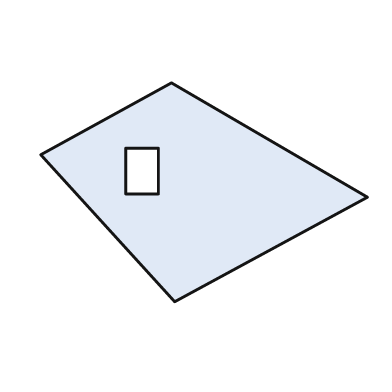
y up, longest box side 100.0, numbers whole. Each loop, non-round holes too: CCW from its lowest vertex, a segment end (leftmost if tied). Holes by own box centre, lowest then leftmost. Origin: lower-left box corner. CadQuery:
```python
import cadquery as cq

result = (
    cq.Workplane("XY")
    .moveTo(41.0, 0.0)
    .lineTo(100.0, 32.0)
    .lineTo(40.0, 67.0)
    .lineTo(0.0, 45.0)
    .close()
    .moveTo(26.0, 33.0)
    .lineTo(36.0, 33.0)
    .lineTo(36.0, 47.0)
    .lineTo(26.0, 47.0)
    .close()
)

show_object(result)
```